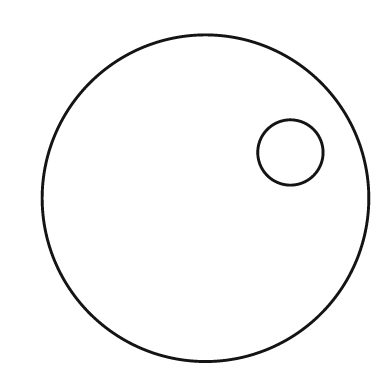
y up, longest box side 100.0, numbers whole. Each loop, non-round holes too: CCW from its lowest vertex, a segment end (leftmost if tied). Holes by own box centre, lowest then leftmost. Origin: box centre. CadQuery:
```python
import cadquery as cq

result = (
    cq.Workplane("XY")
    .moveTo(0.0, 0.0)
    .circle(50.0)
    .moveTo(26.0, 14.0)
    .circle(10.0)
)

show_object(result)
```